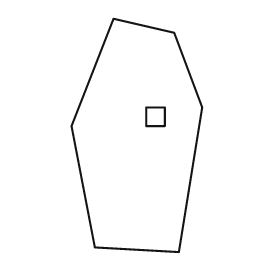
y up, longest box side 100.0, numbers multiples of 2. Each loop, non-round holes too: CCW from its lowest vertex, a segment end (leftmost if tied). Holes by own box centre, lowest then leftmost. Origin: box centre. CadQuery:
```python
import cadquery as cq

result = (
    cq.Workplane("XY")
    .moveTo(18.0, -50.0)
    .lineTo(28.0, 12.0)
    .lineTo(16.0, 44.0)
    .lineTo(-10.0, 50.0)
    .lineTo(-28.0, 4.0)
    .lineTo(-18.0, -48.0)
    .close()
    .moveTo(4.0, 4.0)
    .lineTo(12.0, 4.0)
    .lineTo(12.0, 12.0)
    .lineTo(4.0, 12.0)
    .close()
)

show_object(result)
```